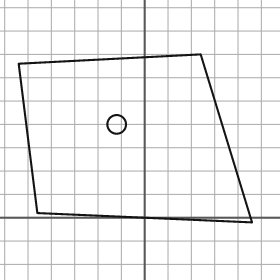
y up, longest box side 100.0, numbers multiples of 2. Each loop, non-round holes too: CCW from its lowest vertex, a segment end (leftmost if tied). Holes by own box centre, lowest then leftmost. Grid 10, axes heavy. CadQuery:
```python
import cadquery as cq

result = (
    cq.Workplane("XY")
    .moveTo(46.0, -2.0)
    .lineTo(24.0, 70.0)
    .lineTo(-54.0, 66.0)
    .lineTo(-46.0, 2.0)
    .close()
    .moveTo(-12.0, 40.0)
    .circle(4.0)
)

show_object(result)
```